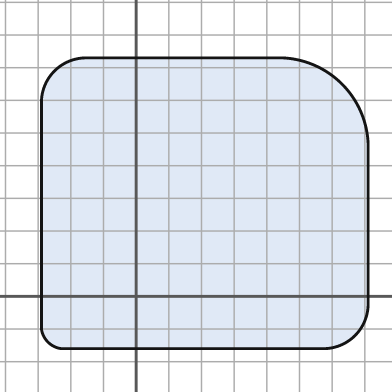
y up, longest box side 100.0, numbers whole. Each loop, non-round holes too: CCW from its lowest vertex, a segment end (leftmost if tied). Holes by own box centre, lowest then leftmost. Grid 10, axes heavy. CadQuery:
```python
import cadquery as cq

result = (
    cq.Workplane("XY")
    .moveTo(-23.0, -16.0)
    .lineTo(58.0, -16.0)
    .threePointArc((67.0, -12.0), (71.0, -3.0))
    .lineTo(71.0, 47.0)
    .threePointArc((63.0, 65.0), (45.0, 73.0))
    .lineTo(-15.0, 73.0)
    .threePointArc((-25.0, 69.0), (-29.0, 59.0))
    .lineTo(-29.0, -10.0)
    .threePointArc((-27.0, -14.0), (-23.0, -16.0))
    .close()
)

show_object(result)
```